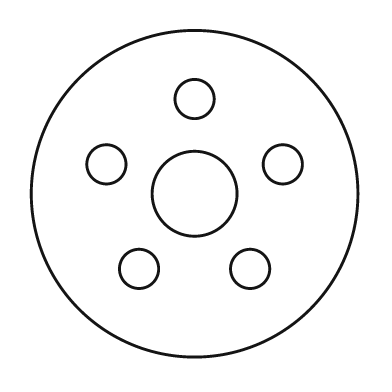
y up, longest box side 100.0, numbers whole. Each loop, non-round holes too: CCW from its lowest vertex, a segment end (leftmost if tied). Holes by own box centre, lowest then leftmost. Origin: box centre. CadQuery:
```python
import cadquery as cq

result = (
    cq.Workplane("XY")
    .moveTo(0.0, 0.0)
    .circle(50.0)
    .moveTo(-17.0, -23.0)
    .circle(6.0)
    .moveTo(17.0, -23.0)
    .circle(6.0)
    .moveTo(0.0, 0.0)
    .circle(13.0)
    .moveTo(-27.0, 9.0)
    .circle(6.0)
    .moveTo(27.0, 9.0)
    .circle(6.0)
    .moveTo(0.0, 29.0)
    .circle(6.0)
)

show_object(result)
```